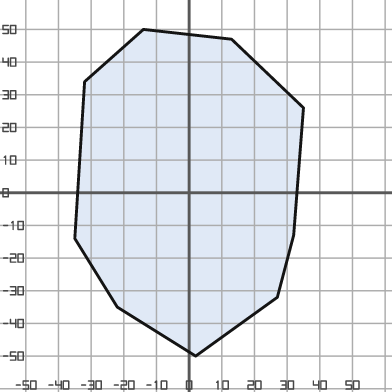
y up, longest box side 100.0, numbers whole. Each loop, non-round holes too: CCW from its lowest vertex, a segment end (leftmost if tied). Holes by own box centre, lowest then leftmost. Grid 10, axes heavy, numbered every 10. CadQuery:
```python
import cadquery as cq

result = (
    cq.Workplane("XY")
    .moveTo(2.0, -50.0)
    .lineTo(27.0, -32.0)
    .lineTo(32.0, -13.0)
    .lineTo(35.0, 26.0)
    .lineTo(13.0, 47.0)
    .lineTo(-14.0, 50.0)
    .lineTo(-32.0, 34.0)
    .lineTo(-35.0, -14.0)
    .lineTo(-22.0, -35.0)
    .close()
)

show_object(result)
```